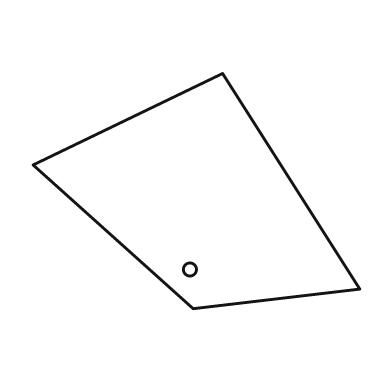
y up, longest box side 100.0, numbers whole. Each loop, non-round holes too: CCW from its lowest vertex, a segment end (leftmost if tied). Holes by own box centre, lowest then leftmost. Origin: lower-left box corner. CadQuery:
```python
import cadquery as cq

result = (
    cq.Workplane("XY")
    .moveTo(49.0, 0.0)
    .lineTo(100.0, 6.0)
    .lineTo(58.0, 72.0)
    .lineTo(0.0, 44.0)
    .close()
    .moveTo(48.0, 12.0)
    .circle(2.0)
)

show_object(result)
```